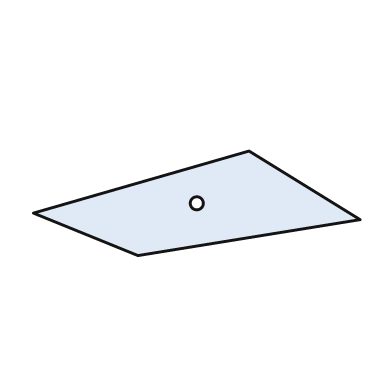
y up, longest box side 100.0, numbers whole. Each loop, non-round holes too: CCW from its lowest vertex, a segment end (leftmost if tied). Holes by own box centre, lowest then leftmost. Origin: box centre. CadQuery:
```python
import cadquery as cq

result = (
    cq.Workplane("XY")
    .moveTo(-18.0, -16.0)
    .lineTo(50.0, -5.0)
    .lineTo(16.0, 16.0)
    .lineTo(-50.0, -3.0)
    .close()
    .moveTo(0.0, 0.0)
    .circle(2.0)
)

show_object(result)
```